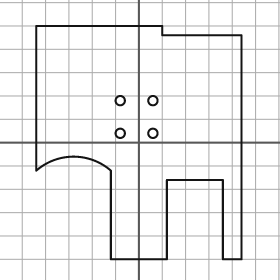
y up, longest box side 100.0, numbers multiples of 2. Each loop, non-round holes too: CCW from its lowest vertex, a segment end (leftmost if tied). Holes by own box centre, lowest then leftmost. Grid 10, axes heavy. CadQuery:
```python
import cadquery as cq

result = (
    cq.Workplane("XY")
    .moveTo(-12.0, -50.0)
    .lineTo(12.0, -50.0)
    .lineTo(12.0, -16.0)
    .lineTo(36.0, -16.0)
    .lineTo(36.0, -50.0)
    .lineTo(44.0, -50.0)
    .lineTo(44.0, 46.0)
    .lineTo(10.0, 46.0)
    .lineTo(10.0, 50.0)
    .lineTo(-44.0, 50.0)
    .lineTo(-44.0, -12.0)
    .threePointArc((-28.0, -6.0), (-12.0, -12.0))
    .close()
    .moveTo(-8.0, 4.0)
    .circle(2.0)
    .moveTo(6.0, 4.0)
    .circle(2.0)
    .moveTo(-8.0, 18.0)
    .circle(2.0)
    .moveTo(6.0, 18.0)
    .circle(2.0)
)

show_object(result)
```